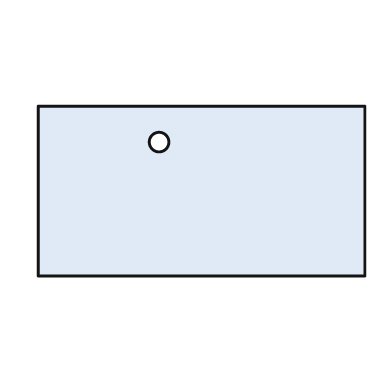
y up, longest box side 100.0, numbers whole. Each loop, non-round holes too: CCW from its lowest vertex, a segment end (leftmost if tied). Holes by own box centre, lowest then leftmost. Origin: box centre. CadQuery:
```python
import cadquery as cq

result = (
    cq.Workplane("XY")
    .moveTo(-50.0, -26.0)
    .lineTo(50.0, -26.0)
    .lineTo(50.0, 26.0)
    .lineTo(-50.0, 26.0)
    .close()
    .moveTo(-13.0, 15.0)
    .circle(3.0)
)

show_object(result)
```